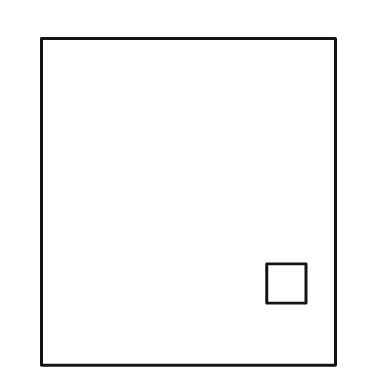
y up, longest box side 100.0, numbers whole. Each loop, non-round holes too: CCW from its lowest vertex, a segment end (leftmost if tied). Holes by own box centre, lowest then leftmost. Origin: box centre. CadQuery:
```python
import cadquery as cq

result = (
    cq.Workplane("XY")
    .moveTo(-45.0, -50.0)
    .lineTo(45.0, -50.0)
    .lineTo(45.0, 50.0)
    .lineTo(-45.0, 50.0)
    .close()
    .moveTo(24.0, -31.0)
    .lineTo(36.0, -31.0)
    .lineTo(36.0, -19.0)
    .lineTo(24.0, -19.0)
    .close()
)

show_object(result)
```